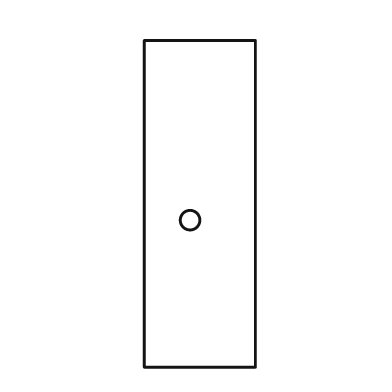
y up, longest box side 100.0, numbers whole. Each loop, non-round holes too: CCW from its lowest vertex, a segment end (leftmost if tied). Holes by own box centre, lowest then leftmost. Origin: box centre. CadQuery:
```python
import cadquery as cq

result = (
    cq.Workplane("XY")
    .moveTo(-17.0, -50.0)
    .lineTo(17.0, -50.0)
    .lineTo(17.0, 50.0)
    .lineTo(-17.0, 50.0)
    .close()
    .moveTo(-3.0, -5.0)
    .circle(3.0)
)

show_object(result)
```